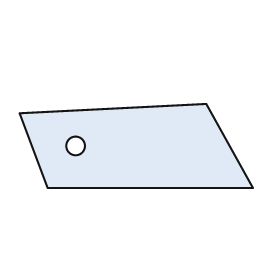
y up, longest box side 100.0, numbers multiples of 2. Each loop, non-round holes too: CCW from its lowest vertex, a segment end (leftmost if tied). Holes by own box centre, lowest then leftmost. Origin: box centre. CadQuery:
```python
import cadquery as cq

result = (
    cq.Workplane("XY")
    .moveTo(-38.0, -18.0)
    .lineTo(50.0, -18.0)
    .lineTo(30.0, 18.0)
    .lineTo(-50.0, 14.0)
    .close()
    .moveTo(-26.0, 0.0)
    .circle(4.0)
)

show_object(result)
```